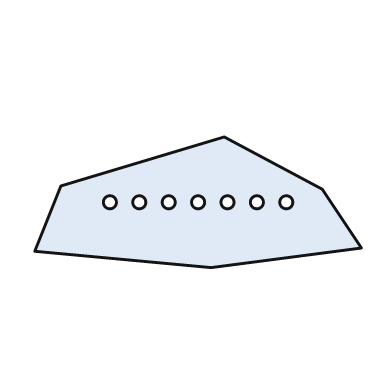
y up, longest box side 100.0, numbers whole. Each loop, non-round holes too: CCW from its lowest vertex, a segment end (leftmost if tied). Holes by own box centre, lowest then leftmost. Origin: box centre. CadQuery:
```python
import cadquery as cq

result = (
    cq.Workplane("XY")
    .moveTo(4.0, -20.0)
    .lineTo(50.0, -14.0)
    .lineTo(38.0, 4.0)
    .lineTo(8.0, 20.0)
    .lineTo(-42.0, 5.0)
    .lineTo(-50.0, -15.0)
    .close()
    .moveTo(-27.0, 0.0)
    .circle(2.0)
    .moveTo(-18.0, 0.0)
    .circle(2.0)
    .moveTo(-9.0, 0.0)
    .circle(2.0)
    .moveTo(0.0, 0.0)
    .circle(2.0)
    .moveTo(9.0, 0.0)
    .circle(2.0)
    .moveTo(18.0, 0.0)
    .circle(2.0)
    .moveTo(27.0, 0.0)
    .circle(2.0)
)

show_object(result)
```